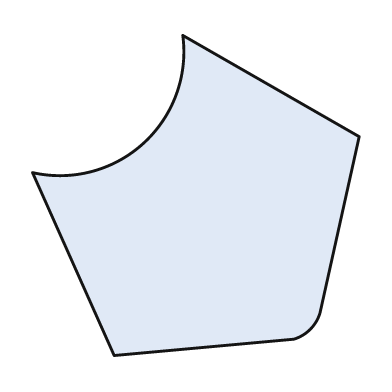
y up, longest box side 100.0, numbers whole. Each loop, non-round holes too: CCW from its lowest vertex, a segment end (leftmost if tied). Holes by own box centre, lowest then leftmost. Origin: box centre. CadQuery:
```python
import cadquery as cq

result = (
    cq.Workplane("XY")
    .moveTo(-25.0, -49.0)
    .lineTo(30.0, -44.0)
    .threePointArc((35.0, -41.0), (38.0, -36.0))
    .lineTo(50.0, 18.0)
    .lineTo(-4.0, 49.0)
    .threePointArc((-16.0, 16.0), (-50.0, 7.0))
    .close()
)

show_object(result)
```